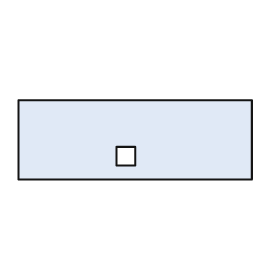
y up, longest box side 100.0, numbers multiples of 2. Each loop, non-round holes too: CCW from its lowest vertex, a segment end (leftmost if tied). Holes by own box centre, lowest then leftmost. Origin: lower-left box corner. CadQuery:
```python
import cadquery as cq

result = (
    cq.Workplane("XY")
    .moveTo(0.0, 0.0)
    .lineTo(100.0, 0.0)
    .lineTo(100.0, 34.0)
    .lineTo(0.0, 34.0)
    .close()
    .moveTo(42.0, 6.0)
    .lineTo(50.0, 6.0)
    .lineTo(50.0, 14.0)
    .lineTo(42.0, 14.0)
    .close()
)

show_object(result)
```